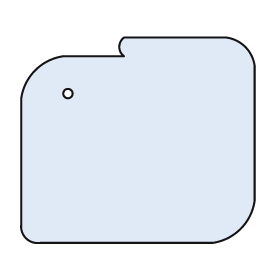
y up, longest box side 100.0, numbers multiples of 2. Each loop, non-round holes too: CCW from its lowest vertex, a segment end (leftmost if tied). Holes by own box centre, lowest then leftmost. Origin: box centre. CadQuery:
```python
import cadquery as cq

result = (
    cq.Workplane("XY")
    .moveTo(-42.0, -44.0)
    .lineTo(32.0, -44.0)
    .threePointArc((44.0, -38.0), (50.0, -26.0))
    .lineTo(50.0, 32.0)
    .threePointArc((46.0, 40.0), (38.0, 44.0))
    .lineTo(-6.0, 44.0)
    .threePointArc((-8.0, 40.0), (-6.0, 36.0))
    .lineTo(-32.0, 36.0)
    .threePointArc((-44.0, 30.0), (-50.0, 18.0))
    .lineTo(-50.0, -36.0)
    .threePointArc((-48.0, -42.0), (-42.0, -44.0))
    .close()
    .moveTo(-30.0, 20.0)
    .circle(2.0)
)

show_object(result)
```